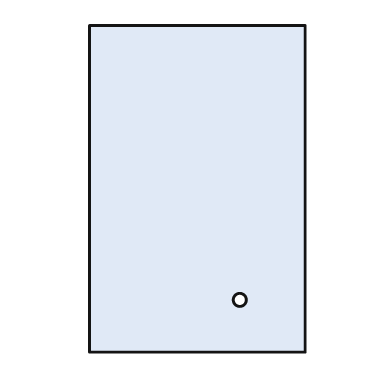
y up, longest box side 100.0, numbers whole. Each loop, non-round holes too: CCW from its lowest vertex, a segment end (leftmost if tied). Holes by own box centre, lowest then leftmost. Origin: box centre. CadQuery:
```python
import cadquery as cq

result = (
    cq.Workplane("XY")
    .moveTo(-33.0, -50.0)
    .lineTo(33.0, -50.0)
    .lineTo(33.0, 50.0)
    .lineTo(-33.0, 50.0)
    .close()
    .moveTo(13.0, -34.0)
    .circle(2.0)
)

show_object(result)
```